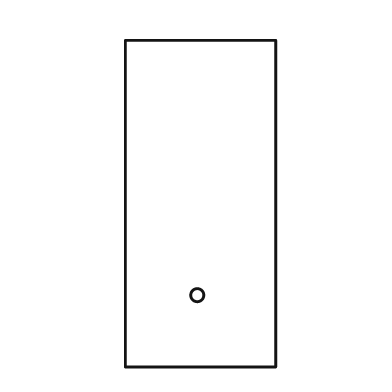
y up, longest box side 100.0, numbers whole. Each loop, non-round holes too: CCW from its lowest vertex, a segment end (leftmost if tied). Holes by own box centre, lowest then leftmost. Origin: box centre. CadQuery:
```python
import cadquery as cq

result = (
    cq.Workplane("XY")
    .moveTo(-23.0, -50.0)
    .lineTo(23.0, -50.0)
    .lineTo(23.0, 50.0)
    .lineTo(-23.0, 50.0)
    .close()
    .moveTo(-1.0, -28.0)
    .circle(2.0)
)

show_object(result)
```